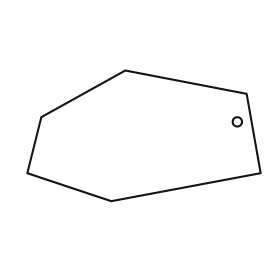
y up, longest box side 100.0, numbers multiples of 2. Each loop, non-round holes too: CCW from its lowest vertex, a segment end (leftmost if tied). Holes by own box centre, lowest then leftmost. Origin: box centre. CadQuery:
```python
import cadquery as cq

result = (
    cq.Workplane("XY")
    .moveTo(-14.0, -28.0)
    .lineTo(50.0, -16.0)
    .lineTo(44.0, 18.0)
    .lineTo(-8.0, 28.0)
    .lineTo(-44.0, 8.0)
    .lineTo(-50.0, -16.0)
    .close()
    .moveTo(40.0, 6.0)
    .circle(2.0)
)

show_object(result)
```